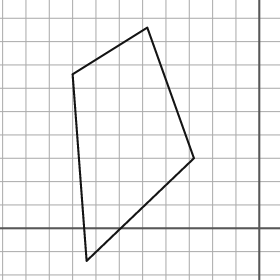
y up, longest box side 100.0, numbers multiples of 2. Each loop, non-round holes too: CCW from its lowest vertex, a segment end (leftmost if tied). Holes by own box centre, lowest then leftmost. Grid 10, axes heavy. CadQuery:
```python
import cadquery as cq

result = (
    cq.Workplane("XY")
    .moveTo(-74.0, -14.0)
    .lineTo(-28.0, 30.0)
    .lineTo(-48.0, 86.0)
    .lineTo(-80.0, 66.0)
    .close()
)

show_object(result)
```